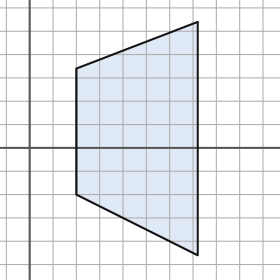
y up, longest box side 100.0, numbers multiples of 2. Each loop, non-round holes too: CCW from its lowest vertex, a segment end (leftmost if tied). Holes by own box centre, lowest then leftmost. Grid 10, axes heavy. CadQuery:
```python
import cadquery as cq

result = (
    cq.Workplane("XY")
    .moveTo(72.0, -46.0)
    .lineTo(72.0, 54.0)
    .lineTo(20.0, 34.0)
    .lineTo(20.0, -20.0)
    .close()
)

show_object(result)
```